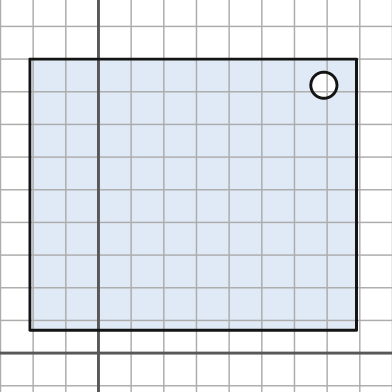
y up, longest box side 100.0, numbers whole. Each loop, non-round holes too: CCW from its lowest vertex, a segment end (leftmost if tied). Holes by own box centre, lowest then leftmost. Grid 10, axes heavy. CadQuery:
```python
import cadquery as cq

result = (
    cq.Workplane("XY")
    .moveTo(-21.0, 7.0)
    .lineTo(79.0, 7.0)
    .lineTo(79.0, 90.0)
    .lineTo(-21.0, 90.0)
    .close()
    .moveTo(69.0, 82.0)
    .circle(4.0)
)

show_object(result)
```